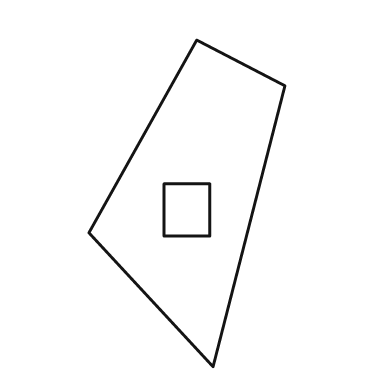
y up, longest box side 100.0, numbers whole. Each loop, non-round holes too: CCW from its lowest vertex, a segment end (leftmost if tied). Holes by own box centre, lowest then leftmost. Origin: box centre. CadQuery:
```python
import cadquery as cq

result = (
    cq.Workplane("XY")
    .moveTo(8.0, -50.0)
    .lineTo(30.0, 36.0)
    .lineTo(3.0, 50.0)
    .lineTo(-30.0, -9.0)
    .close()
    .moveTo(-7.0, -10.0)
    .lineTo(7.0, -10.0)
    .lineTo(7.0, 6.0)
    .lineTo(-7.0, 6.0)
    .close()
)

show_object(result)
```